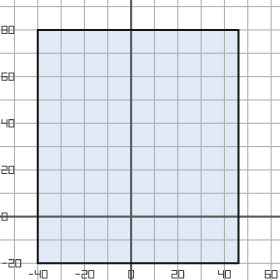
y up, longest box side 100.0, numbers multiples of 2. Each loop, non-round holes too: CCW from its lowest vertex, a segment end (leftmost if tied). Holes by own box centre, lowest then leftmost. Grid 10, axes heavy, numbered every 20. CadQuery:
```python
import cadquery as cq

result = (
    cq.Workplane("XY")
    .moveTo(-40.0, -20.0)
    .lineTo(46.0, -20.0)
    .lineTo(46.0, 80.0)
    .lineTo(-40.0, 80.0)
    .close()
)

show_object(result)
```